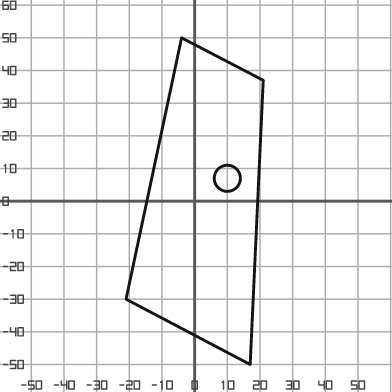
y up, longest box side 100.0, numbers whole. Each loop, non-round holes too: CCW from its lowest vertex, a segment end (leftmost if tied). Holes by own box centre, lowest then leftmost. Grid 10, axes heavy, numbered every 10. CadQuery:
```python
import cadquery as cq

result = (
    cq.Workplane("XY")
    .moveTo(17.0, -50.0)
    .lineTo(21.0, 37.0)
    .lineTo(-4.0, 50.0)
    .lineTo(-21.0, -30.0)
    .close()
    .moveTo(10.0, 7.0)
    .circle(4.0)
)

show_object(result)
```